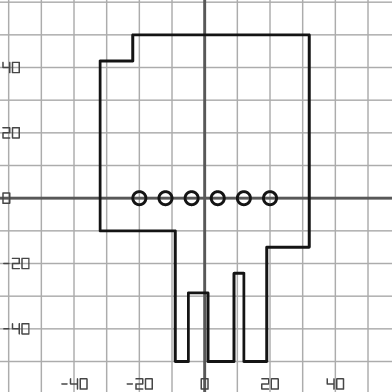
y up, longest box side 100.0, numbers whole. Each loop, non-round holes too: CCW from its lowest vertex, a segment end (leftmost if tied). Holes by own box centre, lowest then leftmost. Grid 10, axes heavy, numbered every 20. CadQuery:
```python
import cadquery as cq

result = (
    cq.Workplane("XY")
    .moveTo(-9.0, -50.0)
    .lineTo(-5.0, -50.0)
    .lineTo(-5.0, -29.0)
    .lineTo(1.0, -29.0)
    .lineTo(1.0, -50.0)
    .lineTo(9.0, -50.0)
    .lineTo(9.0, -23.0)
    .lineTo(12.0, -23.0)
    .lineTo(12.0, -50.0)
    .lineTo(19.0, -50.0)
    .lineTo(19.0, -15.0)
    .lineTo(32.0, -15.0)
    .lineTo(32.0, 50.0)
    .lineTo(-22.0, 50.0)
    .lineTo(-22.0, 42.0)
    .lineTo(-32.0, 42.0)
    .lineTo(-32.0, -10.0)
    .lineTo(-9.0, -10.0)
    .close()
    .moveTo(-20.0, 0.0)
    .circle(2.0)
    .moveTo(-12.0, 0.0)
    .circle(2.0)
    .moveTo(-4.0, 0.0)
    .circle(2.0)
    .moveTo(4.0, 0.0)
    .circle(2.0)
    .moveTo(12.0, 0.0)
    .circle(2.0)
    .moveTo(20.0, 0.0)
    .circle(2.0)
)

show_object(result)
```